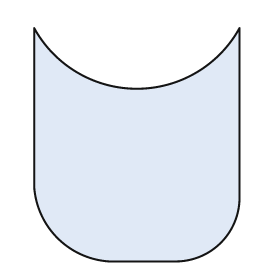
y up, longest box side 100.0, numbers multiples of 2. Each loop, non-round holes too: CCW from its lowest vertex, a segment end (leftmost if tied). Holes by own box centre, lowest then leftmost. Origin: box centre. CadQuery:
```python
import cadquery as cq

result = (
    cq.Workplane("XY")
    .moveTo(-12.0, -50.0)
    .lineTo(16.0, -50.0)
    .threePointArc((36.0, -42.0), (44.0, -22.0))
    .lineTo(44.0, 50.0)
    .threePointArc((0.0, 24.0), (-44.0, 50.0))
    .lineTo(-44.0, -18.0)
    .threePointArc((-34.0, -40.0), (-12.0, -50.0))
    .close()
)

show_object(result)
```